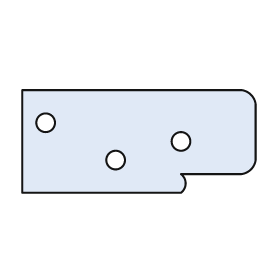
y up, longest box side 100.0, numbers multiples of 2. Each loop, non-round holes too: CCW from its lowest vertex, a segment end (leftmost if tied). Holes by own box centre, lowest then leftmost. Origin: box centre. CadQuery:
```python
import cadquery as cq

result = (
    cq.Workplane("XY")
    .moveTo(-50.0, -22.0)
    .lineTo(18.0, -22.0)
    .threePointArc((20.0, -18.0), (18.0, -14.0))
    .lineTo(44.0, -14.0)
    .threePointArc((48.0, -12.0), (50.0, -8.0))
    .lineTo(50.0, 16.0)
    .threePointArc((48.0, 20.0), (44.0, 22.0))
    .lineTo(-50.0, 22.0)
    .close()
    .moveTo(-10.0, -8.0)
    .circle(4.0)
    .moveTo(18.0, 0.0)
    .circle(4.0)
    .moveTo(-40.0, 8.0)
    .circle(4.0)
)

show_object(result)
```